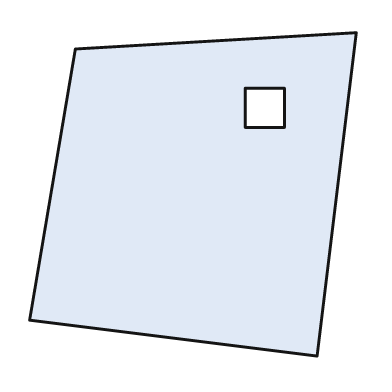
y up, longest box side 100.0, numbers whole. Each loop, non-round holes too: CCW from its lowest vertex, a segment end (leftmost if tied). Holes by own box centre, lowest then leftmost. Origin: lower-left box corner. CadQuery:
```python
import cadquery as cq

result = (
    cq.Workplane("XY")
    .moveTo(88.0, 0.0)
    .lineTo(100.0, 99.0)
    .lineTo(14.0, 94.0)
    .lineTo(0.0, 11.0)
    .close()
    .moveTo(66.0, 70.0)
    .lineTo(78.0, 70.0)
    .lineTo(78.0, 82.0)
    .lineTo(66.0, 82.0)
    .close()
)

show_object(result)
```